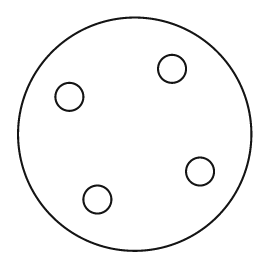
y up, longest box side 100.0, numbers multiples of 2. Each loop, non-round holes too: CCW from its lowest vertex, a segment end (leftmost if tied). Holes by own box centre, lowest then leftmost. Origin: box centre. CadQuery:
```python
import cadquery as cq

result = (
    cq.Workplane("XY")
    .moveTo(0.0, 0.0)
    .circle(50.0)
    .moveTo(-16.0, -28.0)
    .circle(6.0)
    .moveTo(28.0, -16.0)
    .circle(6.0)
    .moveTo(-28.0, 16.0)
    .circle(6.0)
    .moveTo(16.0, 28.0)
    .circle(6.0)
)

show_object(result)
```